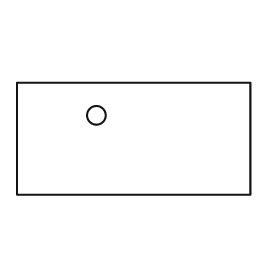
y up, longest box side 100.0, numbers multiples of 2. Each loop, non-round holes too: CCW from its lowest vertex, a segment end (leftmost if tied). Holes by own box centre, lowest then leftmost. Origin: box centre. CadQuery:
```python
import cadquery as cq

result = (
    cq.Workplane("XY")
    .moveTo(-50.0, -24.0)
    .lineTo(50.0, -24.0)
    .lineTo(50.0, 24.0)
    .lineTo(-50.0, 24.0)
    .close()
    .moveTo(-16.0, 10.0)
    .circle(4.0)
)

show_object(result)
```